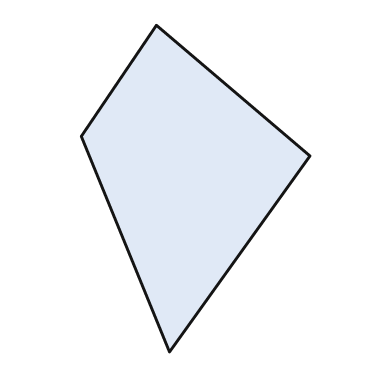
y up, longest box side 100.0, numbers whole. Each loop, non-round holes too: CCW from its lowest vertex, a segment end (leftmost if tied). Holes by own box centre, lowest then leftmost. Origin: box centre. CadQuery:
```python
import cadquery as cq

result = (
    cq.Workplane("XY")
    .moveTo(-8.0, -50.0)
    .lineTo(35.0, 10.0)
    .lineTo(-12.0, 50.0)
    .lineTo(-35.0, 16.0)
    .close()
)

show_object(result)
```